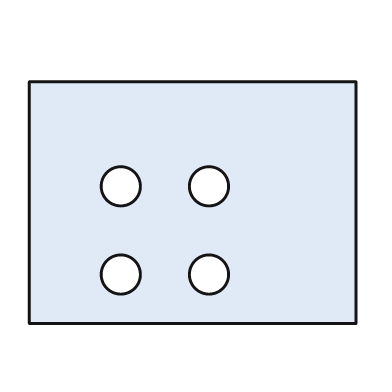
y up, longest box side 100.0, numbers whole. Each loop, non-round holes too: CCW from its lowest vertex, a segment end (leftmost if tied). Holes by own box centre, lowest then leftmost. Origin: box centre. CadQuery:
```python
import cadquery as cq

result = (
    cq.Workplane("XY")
    .moveTo(-50.0, -37.0)
    .lineTo(50.0, -37.0)
    .lineTo(50.0, 37.0)
    .lineTo(-50.0, 37.0)
    .close()
    .moveTo(-22.0, -22.0)
    .circle(6.0)
    .moveTo(5.0, -22.0)
    .circle(6.0)
    .moveTo(-22.0, 5.0)
    .circle(6.0)
    .moveTo(5.0, 5.0)
    .circle(6.0)
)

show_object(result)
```